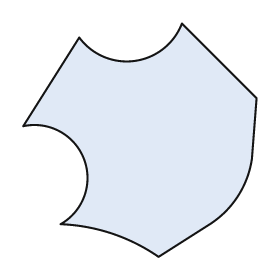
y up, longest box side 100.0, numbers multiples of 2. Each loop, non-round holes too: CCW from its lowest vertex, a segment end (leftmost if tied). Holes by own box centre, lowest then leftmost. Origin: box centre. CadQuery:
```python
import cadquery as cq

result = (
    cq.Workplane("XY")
    .moveTo(8.0, -50.0)
    .lineTo(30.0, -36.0)
    .threePointArc((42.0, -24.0), (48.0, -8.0))
    .lineTo(50.0, 18.0)
    .lineTo(18.0, 50.0)
    .threePointArc((-2.0, 34.0), (-26.0, 44.0))
    .lineTo(-50.0, 6.0)
    .threePointArc((-24.0, -8.0), (-34.0, -36.0))
    .threePointArc((-12.0, -40.0), (8.0, -50.0))
    .close()
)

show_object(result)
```